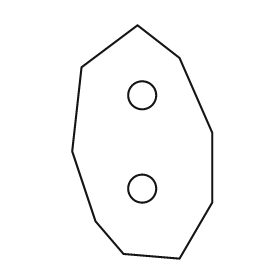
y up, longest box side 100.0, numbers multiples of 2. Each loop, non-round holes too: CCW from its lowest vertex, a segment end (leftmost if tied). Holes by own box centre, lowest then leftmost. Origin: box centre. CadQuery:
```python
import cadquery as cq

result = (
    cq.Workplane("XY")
    .moveTo(16.0, -50.0)
    .lineTo(30.0, -26.0)
    .lineTo(30.0, 4.0)
    .lineTo(16.0, 36.0)
    .lineTo(-2.0, 50.0)
    .lineTo(-26.0, 32.0)
    .lineTo(-30.0, -4.0)
    .lineTo(-20.0, -34.0)
    .lineTo(-8.0, -48.0)
    .close()
    .moveTo(0.0, -20.0)
    .circle(6.0)
    .moveTo(0.0, 20.0)
    .circle(6.0)
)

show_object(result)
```